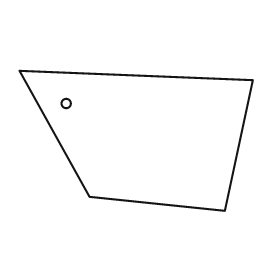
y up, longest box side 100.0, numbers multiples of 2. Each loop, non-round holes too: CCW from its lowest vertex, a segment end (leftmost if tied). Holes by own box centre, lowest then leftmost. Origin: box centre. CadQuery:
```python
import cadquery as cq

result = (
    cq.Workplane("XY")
    .moveTo(38.0, -30.0)
    .lineTo(50.0, 26.0)
    .lineTo(-50.0, 30.0)
    .lineTo(-20.0, -24.0)
    .close()
    .moveTo(-30.0, 16.0)
    .circle(2.0)
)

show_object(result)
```